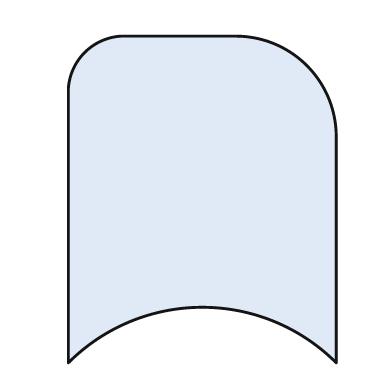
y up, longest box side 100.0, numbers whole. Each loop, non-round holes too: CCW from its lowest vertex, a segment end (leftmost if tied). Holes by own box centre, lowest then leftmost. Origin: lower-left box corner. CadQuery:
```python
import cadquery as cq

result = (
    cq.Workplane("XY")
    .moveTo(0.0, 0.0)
    .threePointArc((41.0, 17.0), (82.0, 0.0))
    .lineTo(82.0, 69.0)
    .threePointArc((73.0, 91.0), (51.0, 100.0))
    .lineTo(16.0, 100.0)
    .threePointArc((5.0, 95.0), (0.0, 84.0))
    .close()
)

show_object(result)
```